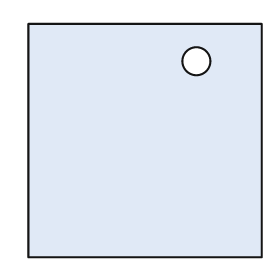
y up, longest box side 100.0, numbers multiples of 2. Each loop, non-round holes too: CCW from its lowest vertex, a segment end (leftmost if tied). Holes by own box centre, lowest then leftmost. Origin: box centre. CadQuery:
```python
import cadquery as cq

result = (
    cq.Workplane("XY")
    .moveTo(-50.0, -50.0)
    .lineTo(50.0, -50.0)
    .lineTo(50.0, 50.0)
    .lineTo(-50.0, 50.0)
    .close()
    .moveTo(22.0, 34.0)
    .circle(6.0)
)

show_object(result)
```